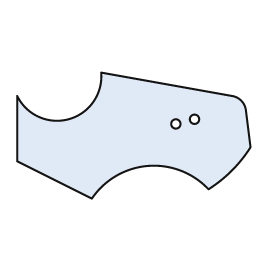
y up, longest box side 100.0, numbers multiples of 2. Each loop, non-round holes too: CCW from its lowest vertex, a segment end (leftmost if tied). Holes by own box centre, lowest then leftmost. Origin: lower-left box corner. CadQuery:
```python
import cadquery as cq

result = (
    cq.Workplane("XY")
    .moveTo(32.0, 0.0)
    .threePointArc((56.0, 14.0), (82.0, 4.0))
    .threePointArc((92.0, 12.0), (100.0, 22.0))
    .lineTo(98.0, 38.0)
    .threePointArc((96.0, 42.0), (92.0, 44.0))
    .lineTo(36.0, 54.0)
    .threePointArc((22.0, 34.0), (0.0, 44.0))
    .lineTo(0.0, 16.0)
    .close()
    .moveTo(68.0, 32.0)
    .circle(2.0)
    .moveTo(76.0, 34.0)
    .circle(2.0)
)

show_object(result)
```